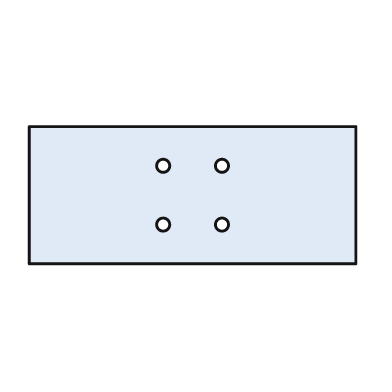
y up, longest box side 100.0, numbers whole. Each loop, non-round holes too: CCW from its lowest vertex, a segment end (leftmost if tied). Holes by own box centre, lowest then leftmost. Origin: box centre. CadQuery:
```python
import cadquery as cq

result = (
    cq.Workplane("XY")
    .moveTo(-50.0, -21.0)
    .lineTo(50.0, -21.0)
    .lineTo(50.0, 21.0)
    .lineTo(-50.0, 21.0)
    .close()
    .moveTo(-9.0, -9.0)
    .circle(2.0)
    .moveTo(9.0, -9.0)
    .circle(2.0)
    .moveTo(-9.0, 9.0)
    .circle(2.0)
    .moveTo(9.0, 9.0)
    .circle(2.0)
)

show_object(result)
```